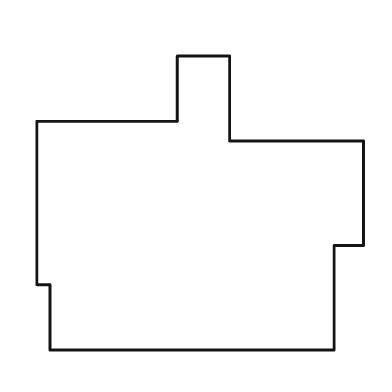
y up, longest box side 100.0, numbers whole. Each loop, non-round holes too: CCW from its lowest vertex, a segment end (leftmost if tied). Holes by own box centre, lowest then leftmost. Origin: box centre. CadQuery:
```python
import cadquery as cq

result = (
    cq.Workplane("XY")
    .moveTo(-46.0, -45.0)
    .lineTo(41.0, -45.0)
    .lineTo(41.0, -13.0)
    .lineTo(50.0, -13.0)
    .lineTo(50.0, 19.0)
    .lineTo(9.0, 19.0)
    .lineTo(9.0, 45.0)
    .lineTo(-7.0, 45.0)
    .lineTo(-7.0, 25.0)
    .lineTo(-50.0, 25.0)
    .lineTo(-50.0, -25.0)
    .lineTo(-46.0, -25.0)
    .close()
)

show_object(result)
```